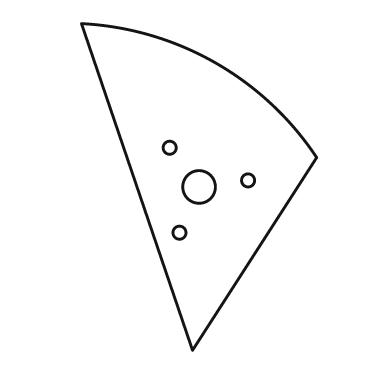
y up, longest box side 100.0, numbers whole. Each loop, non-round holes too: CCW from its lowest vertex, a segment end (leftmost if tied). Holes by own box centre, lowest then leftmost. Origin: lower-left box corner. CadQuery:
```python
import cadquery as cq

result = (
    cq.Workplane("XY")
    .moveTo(34.0, 0.0)
    .lineTo(72.0, 59.0)
    .threePointArc((41.0, 88.0), (0.0, 100.0))
    .close()
    .moveTo(30.0, 36.0)
    .circle(2.0)
    .moveTo(36.0, 50.0)
    .circle(5.0)
    .moveTo(51.0, 52.0)
    .circle(2.0)
    .moveTo(27.0, 62.0)
    .circle(2.0)
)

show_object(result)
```